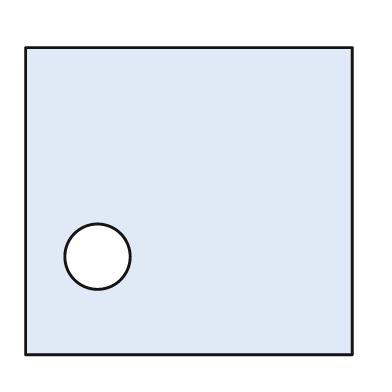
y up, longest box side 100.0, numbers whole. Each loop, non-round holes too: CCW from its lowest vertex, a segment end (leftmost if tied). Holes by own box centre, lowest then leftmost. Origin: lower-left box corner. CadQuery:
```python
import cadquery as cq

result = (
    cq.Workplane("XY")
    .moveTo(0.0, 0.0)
    .lineTo(100.0, 0.0)
    .lineTo(100.0, 94.0)
    .lineTo(0.0, 94.0)
    .close()
    .moveTo(22.0, 30.0)
    .circle(10.0)
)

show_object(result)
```